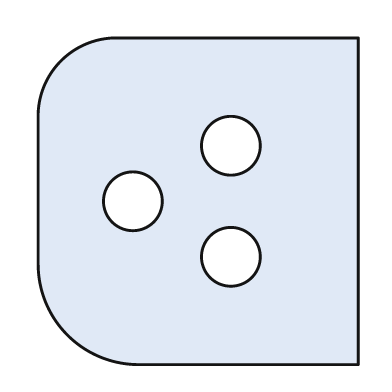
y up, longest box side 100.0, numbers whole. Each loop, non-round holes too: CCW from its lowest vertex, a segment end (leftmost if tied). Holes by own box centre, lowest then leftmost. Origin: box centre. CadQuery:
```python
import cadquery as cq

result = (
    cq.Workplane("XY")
    .moveTo(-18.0, -50.0)
    .lineTo(49.0, -50.0)
    .lineTo(49.0, 50.0)
    .lineTo(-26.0, 50.0)
    .threePointArc((-42.0, 43.0), (-49.0, 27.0))
    .lineTo(-49.0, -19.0)
    .threePointArc((-40.0, -41.0), (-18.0, -50.0))
    .close()
    .moveTo(10.0, -17.0)
    .circle(9.0)
    .moveTo(-20.0, 0.0)
    .circle(9.0)
    .moveTo(10.0, 17.0)
    .circle(9.0)
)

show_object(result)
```